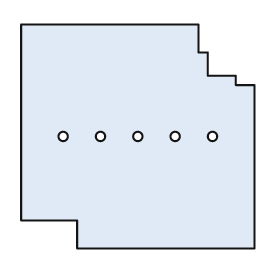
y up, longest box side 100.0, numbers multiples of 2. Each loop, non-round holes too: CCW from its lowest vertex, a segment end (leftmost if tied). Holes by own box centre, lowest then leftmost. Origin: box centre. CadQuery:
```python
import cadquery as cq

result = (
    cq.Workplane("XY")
    .moveTo(-26.0, -48.0)
    .lineTo(50.0, -48.0)
    .lineTo(50.0, 22.0)
    .lineTo(42.0, 22.0)
    .lineTo(42.0, 26.0)
    .lineTo(30.0, 26.0)
    .lineTo(30.0, 36.0)
    .lineTo(26.0, 36.0)
    .lineTo(26.0, 48.0)
    .lineTo(-50.0, 48.0)
    .lineTo(-50.0, -36.0)
    .lineTo(-26.0, -36.0)
    .close()
    .moveTo(-32.0, 0.0)
    .circle(2.0)
    .moveTo(-16.0, 0.0)
    .circle(2.0)
    .moveTo(0.0, 0.0)
    .circle(2.0)
    .moveTo(16.0, 0.0)
    .circle(2.0)
    .moveTo(32.0, 0.0)
    .circle(2.0)
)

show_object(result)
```